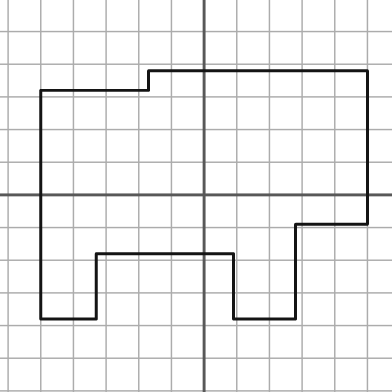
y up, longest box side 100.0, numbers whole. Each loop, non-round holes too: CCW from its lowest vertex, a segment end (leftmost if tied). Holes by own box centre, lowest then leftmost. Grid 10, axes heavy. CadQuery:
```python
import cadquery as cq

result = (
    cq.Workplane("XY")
    .moveTo(-50.0, -38.0)
    .lineTo(-33.0, -38.0)
    .lineTo(-33.0, -18.0)
    .lineTo(9.0, -18.0)
    .lineTo(9.0, -38.0)
    .lineTo(28.0, -38.0)
    .lineTo(28.0, -9.0)
    .lineTo(50.0, -9.0)
    .lineTo(50.0, 38.0)
    .lineTo(-17.0, 38.0)
    .lineTo(-17.0, 32.0)
    .lineTo(-50.0, 32.0)
    .close()
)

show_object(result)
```